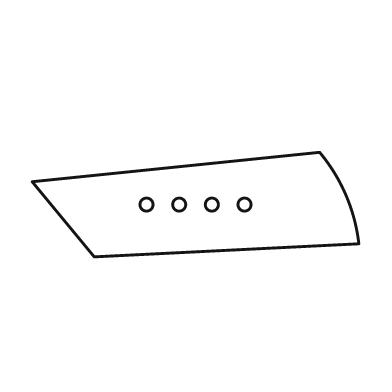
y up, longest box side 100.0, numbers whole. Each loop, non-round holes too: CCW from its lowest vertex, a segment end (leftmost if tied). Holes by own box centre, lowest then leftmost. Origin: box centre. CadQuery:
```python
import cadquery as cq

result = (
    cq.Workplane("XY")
    .moveTo(-31.0, -16.0)
    .lineTo(50.0, -12.0)
    .threePointArc((46.0, 3.0), (38.0, 16.0))
    .lineTo(-50.0, 7.0)
    .close()
    .moveTo(-15.0, 0.0)
    .circle(2.0)
    .moveTo(-5.0, 0.0)
    .circle(2.0)
    .moveTo(5.0, 0.0)
    .circle(2.0)
    .moveTo(15.0, 0.0)
    .circle(2.0)
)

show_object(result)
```